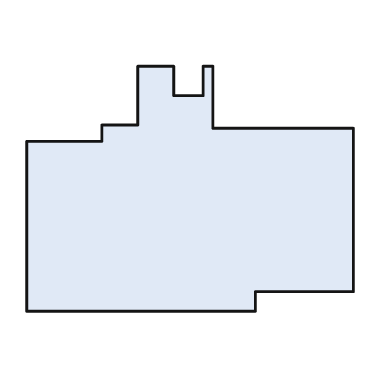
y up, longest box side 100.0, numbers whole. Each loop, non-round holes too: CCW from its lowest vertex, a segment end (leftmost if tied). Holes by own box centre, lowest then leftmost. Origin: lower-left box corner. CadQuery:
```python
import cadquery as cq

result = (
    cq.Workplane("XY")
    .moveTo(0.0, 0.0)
    .lineTo(70.0, 0.0)
    .lineTo(70.0, 6.0)
    .lineTo(100.0, 6.0)
    .lineTo(100.0, 56.0)
    .lineTo(57.0, 56.0)
    .lineTo(57.0, 75.0)
    .lineTo(54.0, 75.0)
    .lineTo(54.0, 66.0)
    .lineTo(45.0, 66.0)
    .lineTo(45.0, 75.0)
    .lineTo(34.0, 75.0)
    .lineTo(34.0, 57.0)
    .lineTo(23.0, 57.0)
    .lineTo(23.0, 52.0)
    .lineTo(0.0, 52.0)
    .close()
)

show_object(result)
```